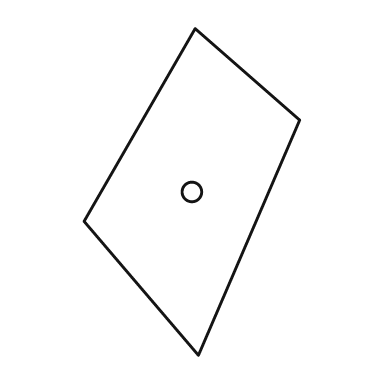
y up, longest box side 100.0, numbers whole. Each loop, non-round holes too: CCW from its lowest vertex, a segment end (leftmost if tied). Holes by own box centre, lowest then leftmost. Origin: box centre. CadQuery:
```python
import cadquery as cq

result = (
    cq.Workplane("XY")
    .moveTo(2.0, -50.0)
    .lineTo(33.0, 22.0)
    .lineTo(1.0, 50.0)
    .lineTo(-33.0, -9.0)
    .close()
    .moveTo(0.0, 0.0)
    .circle(3.0)
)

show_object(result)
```